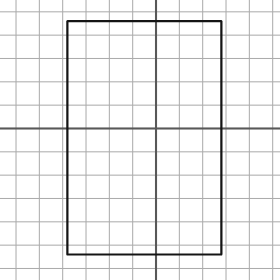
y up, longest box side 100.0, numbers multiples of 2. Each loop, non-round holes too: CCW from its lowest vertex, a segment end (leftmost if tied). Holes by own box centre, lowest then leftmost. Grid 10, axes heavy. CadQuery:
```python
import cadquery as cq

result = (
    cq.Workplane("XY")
    .moveTo(-38.0, -54.0)
    .lineTo(28.0, -54.0)
    .lineTo(28.0, 46.0)
    .lineTo(-38.0, 46.0)
    .close()
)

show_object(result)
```